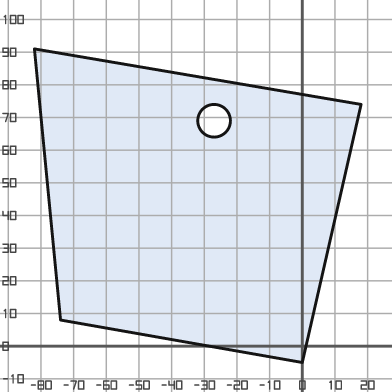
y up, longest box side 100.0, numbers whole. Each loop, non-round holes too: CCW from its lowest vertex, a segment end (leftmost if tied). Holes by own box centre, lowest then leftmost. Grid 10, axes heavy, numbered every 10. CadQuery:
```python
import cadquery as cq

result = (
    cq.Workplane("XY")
    .moveTo(0.0, -5.0)
    .lineTo(18.0, 74.0)
    .lineTo(-82.0, 91.0)
    .lineTo(-74.0, 8.0)
    .close()
    .moveTo(-27.0, 69.0)
    .circle(5.0)
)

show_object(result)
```